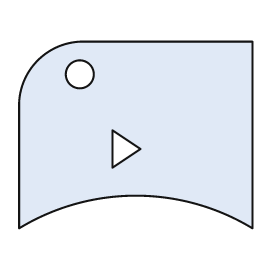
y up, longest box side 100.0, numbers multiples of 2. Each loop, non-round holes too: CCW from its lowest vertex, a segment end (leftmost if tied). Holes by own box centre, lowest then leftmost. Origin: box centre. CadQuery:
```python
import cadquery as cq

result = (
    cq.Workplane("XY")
    .moveTo(-50.0, -40.0)
    .threePointArc((0.0, -26.0), (50.0, -40.0))
    .lineTo(50.0, 40.0)
    .lineTo(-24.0, 40.0)
    .threePointArc((-42.0, 32.0), (-50.0, 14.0))
    .close()
    .moveTo(-10.0, -14.0)
    .lineTo(2.0, -6.0)
    .lineTo(-10.0, 2.0)
    .close()
    .moveTo(-24.0, 26.0)
    .circle(6.0)
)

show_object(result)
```